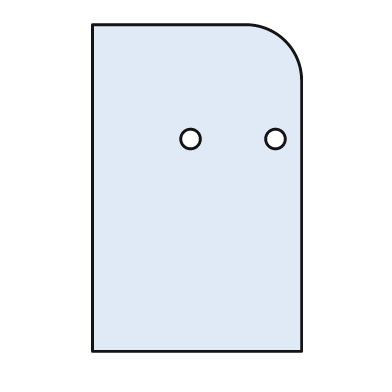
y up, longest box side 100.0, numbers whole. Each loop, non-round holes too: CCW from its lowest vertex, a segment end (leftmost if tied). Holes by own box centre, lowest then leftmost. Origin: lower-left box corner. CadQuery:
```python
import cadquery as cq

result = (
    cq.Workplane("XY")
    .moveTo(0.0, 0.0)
    .lineTo(64.0, 0.0)
    .lineTo(64.0, 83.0)
    .threePointArc((59.0, 95.0), (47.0, 100.0))
    .lineTo(0.0, 100.0)
    .close()
    .moveTo(30.0, 65.0)
    .circle(3.0)
    .moveTo(56.0, 65.0)
    .circle(3.0)
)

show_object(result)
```